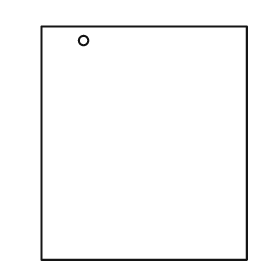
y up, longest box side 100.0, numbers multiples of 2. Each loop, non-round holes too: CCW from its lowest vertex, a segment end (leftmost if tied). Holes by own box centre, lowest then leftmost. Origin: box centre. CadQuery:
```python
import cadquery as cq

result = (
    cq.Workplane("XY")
    .moveTo(-44.0, -50.0)
    .lineTo(44.0, -50.0)
    .lineTo(44.0, 50.0)
    .lineTo(-44.0, 50.0)
    .close()
    .moveTo(-26.0, 44.0)
    .circle(2.0)
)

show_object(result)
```